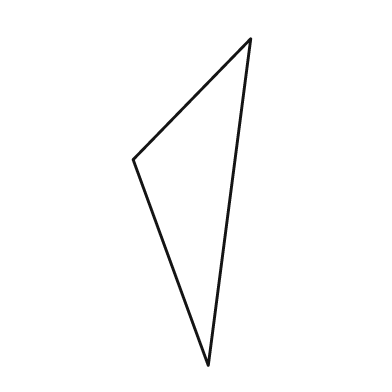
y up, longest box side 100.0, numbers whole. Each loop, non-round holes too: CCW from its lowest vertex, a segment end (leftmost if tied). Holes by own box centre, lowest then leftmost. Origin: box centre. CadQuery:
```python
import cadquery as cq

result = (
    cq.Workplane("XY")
    .moveTo(5.0, -50.0)
    .lineTo(18.0, 50.0)
    .lineTo(-18.0, 13.0)
    .close()
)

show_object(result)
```